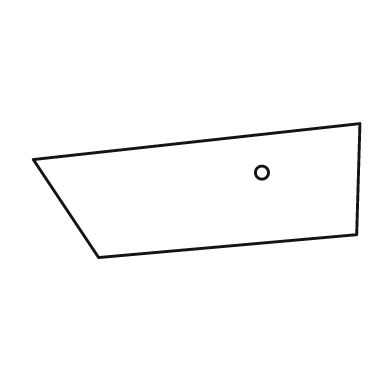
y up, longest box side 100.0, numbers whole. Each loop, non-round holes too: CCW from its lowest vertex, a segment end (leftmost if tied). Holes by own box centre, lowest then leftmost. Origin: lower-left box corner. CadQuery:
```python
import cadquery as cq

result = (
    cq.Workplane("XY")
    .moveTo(20.0, 0.0)
    .lineTo(99.0, 7.0)
    .lineTo(100.0, 41.0)
    .lineTo(0.0, 30.0)
    .close()
    .moveTo(70.0, 26.0)
    .circle(2.0)
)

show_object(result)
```